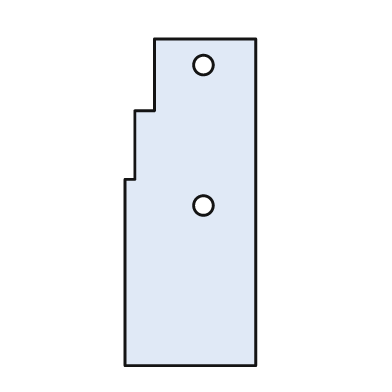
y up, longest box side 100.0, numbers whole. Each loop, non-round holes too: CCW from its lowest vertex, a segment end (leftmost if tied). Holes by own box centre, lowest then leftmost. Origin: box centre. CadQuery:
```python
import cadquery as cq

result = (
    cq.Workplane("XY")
    .moveTo(-20.0, -50.0)
    .lineTo(20.0, -50.0)
    .lineTo(20.0, 50.0)
    .lineTo(-11.0, 50.0)
    .lineTo(-11.0, 28.0)
    .lineTo(-17.0, 28.0)
    .lineTo(-17.0, 7.0)
    .lineTo(-20.0, 7.0)
    .close()
    .moveTo(4.0, -1.0)
    .circle(3.0)
    .moveTo(4.0, 42.0)
    .circle(3.0)
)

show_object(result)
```